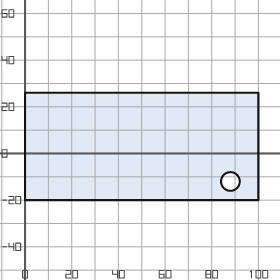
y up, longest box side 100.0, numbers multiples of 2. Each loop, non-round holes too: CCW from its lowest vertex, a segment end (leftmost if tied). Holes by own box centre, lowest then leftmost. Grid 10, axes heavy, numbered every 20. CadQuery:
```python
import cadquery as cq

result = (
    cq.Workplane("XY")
    .moveTo(0.0, -20.0)
    .lineTo(100.0, -20.0)
    .lineTo(100.0, 26.0)
    .lineTo(0.0, 26.0)
    .close()
    .moveTo(88.0, -12.0)
    .circle(4.0)
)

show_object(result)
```